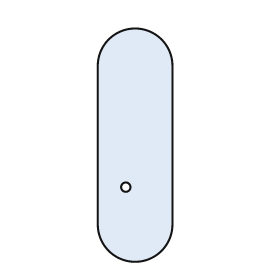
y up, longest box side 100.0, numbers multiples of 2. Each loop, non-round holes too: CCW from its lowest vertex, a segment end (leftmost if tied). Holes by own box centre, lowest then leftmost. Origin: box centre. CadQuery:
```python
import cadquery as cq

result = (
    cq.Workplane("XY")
    .moveTo(-16.0, -34.0)
    .threePointArc((0.0, -50.0), (16.0, -34.0))
    .lineTo(16.0, 34.0)
    .threePointArc((0.0, 50.0), (-16.0, 34.0))
    .close()
    .moveTo(-4.0, -18.0)
    .circle(2.0)
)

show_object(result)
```